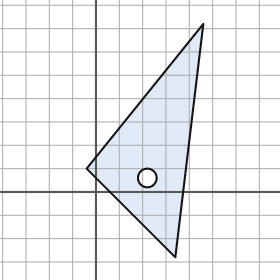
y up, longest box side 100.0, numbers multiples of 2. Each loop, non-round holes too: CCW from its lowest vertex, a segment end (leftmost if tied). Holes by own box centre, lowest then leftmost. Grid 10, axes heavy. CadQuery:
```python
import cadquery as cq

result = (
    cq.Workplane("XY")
    .moveTo(34.0, -28.0)
    .lineTo(46.0, 72.0)
    .lineTo(-4.0, 10.0)
    .close()
    .moveTo(22.0, 6.0)
    .circle(4.0)
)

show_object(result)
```